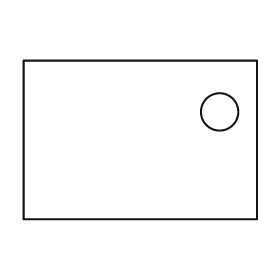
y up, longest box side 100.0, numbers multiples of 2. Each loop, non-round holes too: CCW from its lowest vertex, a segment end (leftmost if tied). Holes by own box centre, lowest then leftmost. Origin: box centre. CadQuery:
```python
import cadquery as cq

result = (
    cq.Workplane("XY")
    .moveTo(-50.0, -34.0)
    .lineTo(50.0, -34.0)
    .lineTo(50.0, 34.0)
    .lineTo(-50.0, 34.0)
    .close()
    .moveTo(34.0, 12.0)
    .circle(8.0)
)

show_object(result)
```